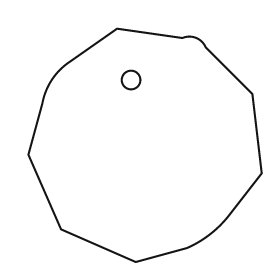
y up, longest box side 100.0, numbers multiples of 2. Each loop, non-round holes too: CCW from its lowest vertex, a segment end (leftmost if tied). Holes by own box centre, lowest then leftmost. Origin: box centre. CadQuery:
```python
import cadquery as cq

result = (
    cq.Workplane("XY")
    .moveTo(-4.0, -50.0)
    .lineTo(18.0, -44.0)
    .threePointArc((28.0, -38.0), (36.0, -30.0))
    .lineTo(50.0, -12.0)
    .lineTo(46.0, 22.0)
    .lineTo(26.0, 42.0)
    .threePointArc((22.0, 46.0), (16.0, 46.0))
    .lineTo(-12.0, 50.0)
    .lineTo(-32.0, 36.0)
    .threePointArc((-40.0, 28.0), (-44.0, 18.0))
    .lineTo(-50.0, -4.0)
    .lineTo(-36.0, -36.0)
    .close()
    .moveTo(-6.0, 28.0)
    .circle(4.0)
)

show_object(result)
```